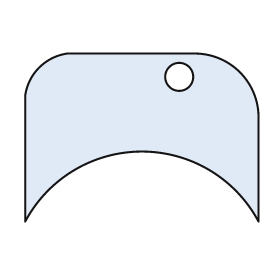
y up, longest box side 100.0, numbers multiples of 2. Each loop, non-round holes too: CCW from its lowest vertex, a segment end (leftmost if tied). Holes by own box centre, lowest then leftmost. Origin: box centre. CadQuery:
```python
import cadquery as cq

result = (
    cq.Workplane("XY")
    .moveTo(-50.0, -36.0)
    .threePointArc((0.0, -6.0), (50.0, -36.0))
    .lineTo(50.0, 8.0)
    .threePointArc((42.0, 28.0), (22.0, 36.0))
    .lineTo(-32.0, 36.0)
    .threePointArc((-44.0, 30.0), (-50.0, 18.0))
    .close()
    .moveTo(16.0, 26.0)
    .circle(6.0)
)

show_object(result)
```